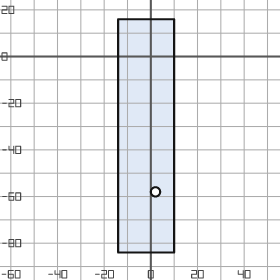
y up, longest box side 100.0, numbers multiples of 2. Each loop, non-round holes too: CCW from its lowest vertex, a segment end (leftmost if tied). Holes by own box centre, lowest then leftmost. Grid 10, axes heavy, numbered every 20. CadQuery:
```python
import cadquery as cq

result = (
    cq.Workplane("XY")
    .moveTo(-14.0, -84.0)
    .lineTo(10.0, -84.0)
    .lineTo(10.0, 16.0)
    .lineTo(-14.0, 16.0)
    .close()
    .moveTo(2.0, -58.0)
    .circle(2.0)
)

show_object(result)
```